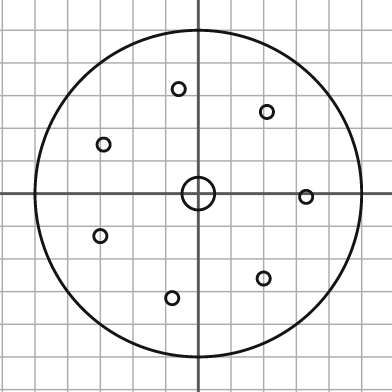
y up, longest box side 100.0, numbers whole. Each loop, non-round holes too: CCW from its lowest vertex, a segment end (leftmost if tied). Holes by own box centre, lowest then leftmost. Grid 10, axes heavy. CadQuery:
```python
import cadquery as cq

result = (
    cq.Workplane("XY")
    .moveTo(0.0, 0.0)
    .circle(50.0)
    .moveTo(-8.0, -32.0)
    .circle(2.0)
    .moveTo(20.0, -26.0)
    .circle(2.0)
    .moveTo(-30.0, -13.0)
    .circle(2.0)
    .moveTo(33.0, -1.0)
    .circle(2.0)
    .moveTo(0.0, 0.0)
    .circle(5.0)
    .moveTo(-29.0, 15.0)
    .circle(2.0)
    .moveTo(21.0, 25.0)
    .circle(2.0)
    .moveTo(-6.0, 32.0)
    .circle(2.0)
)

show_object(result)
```